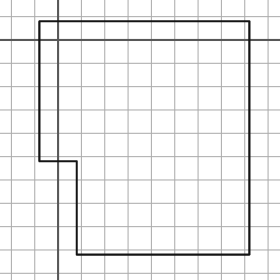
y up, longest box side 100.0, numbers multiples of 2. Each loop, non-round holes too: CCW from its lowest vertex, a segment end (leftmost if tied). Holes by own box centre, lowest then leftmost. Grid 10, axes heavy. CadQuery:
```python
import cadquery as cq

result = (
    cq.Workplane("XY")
    .moveTo(8.0, -92.0)
    .lineTo(82.0, -92.0)
    .lineTo(82.0, 8.0)
    .lineTo(-8.0, 8.0)
    .lineTo(-8.0, -52.0)
    .lineTo(8.0, -52.0)
    .close()
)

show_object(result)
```